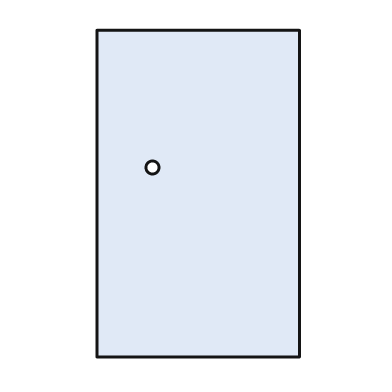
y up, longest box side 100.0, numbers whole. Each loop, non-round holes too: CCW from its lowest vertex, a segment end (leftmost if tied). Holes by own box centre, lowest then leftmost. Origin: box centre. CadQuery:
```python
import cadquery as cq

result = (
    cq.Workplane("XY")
    .moveTo(-31.0, -50.0)
    .lineTo(31.0, -50.0)
    .lineTo(31.0, 50.0)
    .lineTo(-31.0, 50.0)
    .close()
    .moveTo(-14.0, 8.0)
    .circle(2.0)
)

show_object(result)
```